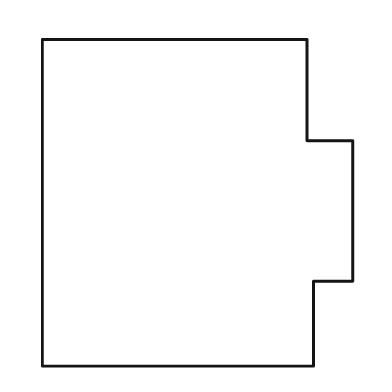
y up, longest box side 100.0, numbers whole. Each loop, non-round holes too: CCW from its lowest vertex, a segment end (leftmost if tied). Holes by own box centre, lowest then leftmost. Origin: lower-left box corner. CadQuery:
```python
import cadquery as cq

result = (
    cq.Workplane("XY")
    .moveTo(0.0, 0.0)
    .lineTo(83.0, 0.0)
    .lineTo(83.0, 26.0)
    .lineTo(95.0, 26.0)
    .lineTo(95.0, 69.0)
    .lineTo(81.0, 69.0)
    .lineTo(81.0, 100.0)
    .lineTo(0.0, 100.0)
    .close()
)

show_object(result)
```